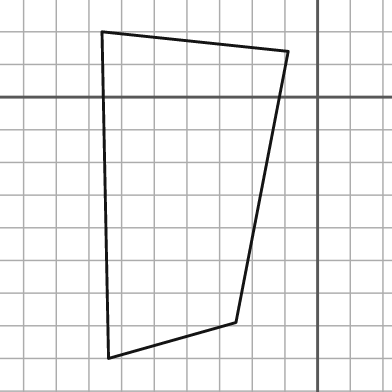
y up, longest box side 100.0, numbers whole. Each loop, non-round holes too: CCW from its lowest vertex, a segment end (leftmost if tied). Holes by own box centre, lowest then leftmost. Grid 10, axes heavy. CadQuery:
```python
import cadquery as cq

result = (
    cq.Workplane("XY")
    .moveTo(-64.0, -80.0)
    .lineTo(-25.0, -69.0)
    .lineTo(-9.0, 14.0)
    .lineTo(-66.0, 20.0)
    .close()
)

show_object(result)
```